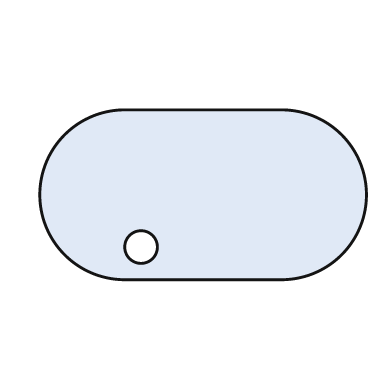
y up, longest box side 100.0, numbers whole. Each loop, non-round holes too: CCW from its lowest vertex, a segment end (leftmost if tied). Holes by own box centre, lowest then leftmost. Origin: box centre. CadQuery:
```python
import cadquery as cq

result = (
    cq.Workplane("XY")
    .moveTo(-24.0, -26.0)
    .lineTo(24.0, -26.0)
    .threePointArc((50.0, 0.0), (24.0, 26.0))
    .lineTo(-24.0, 26.0)
    .threePointArc((-50.0, 0.0), (-24.0, -26.0))
    .close()
    .moveTo(-19.0, -16.0)
    .circle(5.0)
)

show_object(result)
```